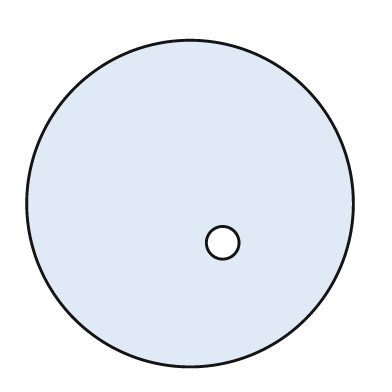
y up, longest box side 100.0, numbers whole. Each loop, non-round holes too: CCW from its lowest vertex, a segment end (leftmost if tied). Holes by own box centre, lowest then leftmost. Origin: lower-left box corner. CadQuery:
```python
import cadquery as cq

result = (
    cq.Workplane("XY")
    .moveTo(50.0, 50.0)
    .circle(50.0)
    .moveTo(60.0, 38.0)
    .circle(5.0)
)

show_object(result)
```